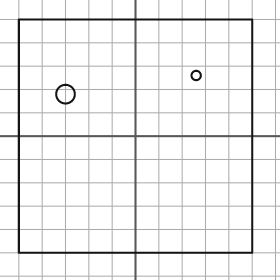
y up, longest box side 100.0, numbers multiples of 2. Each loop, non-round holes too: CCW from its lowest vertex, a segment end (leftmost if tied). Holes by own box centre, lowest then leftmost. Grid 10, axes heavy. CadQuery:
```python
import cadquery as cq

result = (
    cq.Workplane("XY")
    .moveTo(-50.0, -50.0)
    .lineTo(50.0, -50.0)
    .lineTo(50.0, 50.0)
    .lineTo(-50.0, 50.0)
    .close()
    .moveTo(-30.0, 18.0)
    .circle(4.0)
    .moveTo(26.0, 26.0)
    .circle(2.0)
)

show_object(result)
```